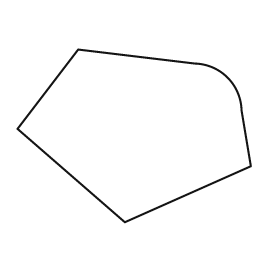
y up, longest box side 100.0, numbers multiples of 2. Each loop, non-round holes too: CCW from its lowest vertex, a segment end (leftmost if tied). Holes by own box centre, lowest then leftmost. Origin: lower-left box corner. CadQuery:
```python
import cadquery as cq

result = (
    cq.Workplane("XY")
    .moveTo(46.0, 0.0)
    .lineTo(100.0, 24.0)
    .lineTo(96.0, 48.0)
    .threePointArc((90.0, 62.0), (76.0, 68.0))
    .lineTo(26.0, 74.0)
    .lineTo(0.0, 40.0)
    .close()
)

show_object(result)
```